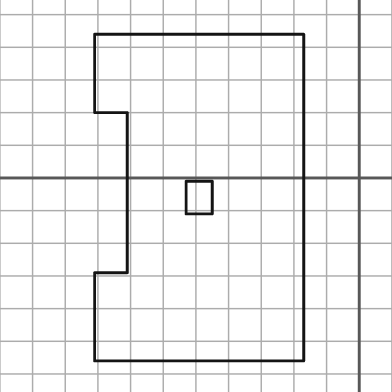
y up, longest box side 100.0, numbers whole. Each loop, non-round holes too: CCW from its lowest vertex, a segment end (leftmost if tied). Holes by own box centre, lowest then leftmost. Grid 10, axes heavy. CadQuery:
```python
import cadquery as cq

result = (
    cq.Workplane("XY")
    .moveTo(-81.0, -56.0)
    .lineTo(-17.0, -56.0)
    .lineTo(-17.0, 44.0)
    .lineTo(-81.0, 44.0)
    .lineTo(-81.0, 20.0)
    .lineTo(-71.0, 20.0)
    .lineTo(-71.0, -29.0)
    .lineTo(-81.0, -29.0)
    .close()
    .moveTo(-53.0, -11.0)
    .lineTo(-45.0, -11.0)
    .lineTo(-45.0, -1.0)
    .lineTo(-53.0, -1.0)
    .close()
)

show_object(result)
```